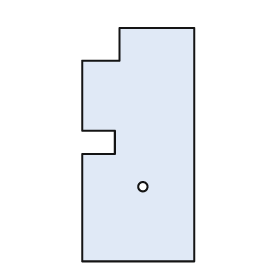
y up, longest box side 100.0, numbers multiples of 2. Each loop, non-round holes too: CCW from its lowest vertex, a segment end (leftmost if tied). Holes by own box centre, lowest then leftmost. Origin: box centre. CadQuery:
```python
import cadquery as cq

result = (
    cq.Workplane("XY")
    .moveTo(-24.0, -50.0)
    .lineTo(24.0, -50.0)
    .lineTo(24.0, 50.0)
    .lineTo(-8.0, 50.0)
    .lineTo(-8.0, 36.0)
    .lineTo(-24.0, 36.0)
    .lineTo(-24.0, 6.0)
    .lineTo(-10.0, 6.0)
    .lineTo(-10.0, -4.0)
    .lineTo(-24.0, -4.0)
    .close()
    .moveTo(2.0, -18.0)
    .circle(2.0)
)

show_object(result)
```